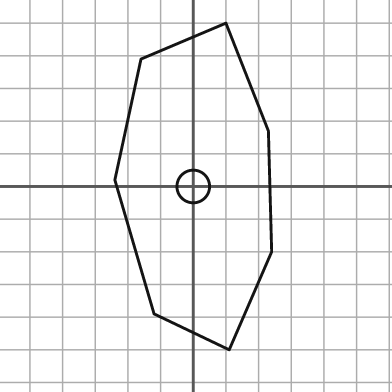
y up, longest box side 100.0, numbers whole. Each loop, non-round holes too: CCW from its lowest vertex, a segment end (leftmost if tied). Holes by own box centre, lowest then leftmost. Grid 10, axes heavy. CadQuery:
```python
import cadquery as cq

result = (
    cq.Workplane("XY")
    .moveTo(11.0, -50.0)
    .lineTo(24.0, -20.0)
    .lineTo(23.0, 17.0)
    .lineTo(10.0, 50.0)
    .lineTo(-16.0, 39.0)
    .lineTo(-24.0, 2.0)
    .lineTo(-12.0, -39.0)
    .close()
    .moveTo(0.0, 0.0)
    .circle(5.0)
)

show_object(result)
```